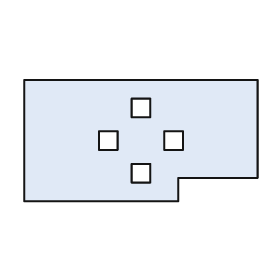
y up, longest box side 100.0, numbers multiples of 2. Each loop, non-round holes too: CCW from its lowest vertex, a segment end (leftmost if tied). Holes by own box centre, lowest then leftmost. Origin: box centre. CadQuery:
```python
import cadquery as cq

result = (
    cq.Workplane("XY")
    .moveTo(-50.0, -26.0)
    .lineTo(16.0, -26.0)
    .lineTo(16.0, -16.0)
    .lineTo(50.0, -16.0)
    .lineTo(50.0, 26.0)
    .lineTo(-50.0, 26.0)
    .close()
    .moveTo(-4.0, -18.0)
    .lineTo(4.0, -18.0)
    .lineTo(4.0, -10.0)
    .lineTo(-4.0, -10.0)
    .close()
    .moveTo(-18.0, -4.0)
    .lineTo(-10.0, -4.0)
    .lineTo(-10.0, 4.0)
    .lineTo(-18.0, 4.0)
    .close()
    .moveTo(10.0, -4.0)
    .lineTo(18.0, -4.0)
    .lineTo(18.0, 4.0)
    .lineTo(10.0, 4.0)
    .close()
    .moveTo(-4.0, 10.0)
    .lineTo(4.0, 10.0)
    .lineTo(4.0, 18.0)
    .lineTo(-4.0, 18.0)
    .close()
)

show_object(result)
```